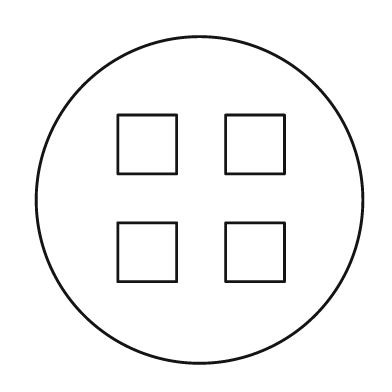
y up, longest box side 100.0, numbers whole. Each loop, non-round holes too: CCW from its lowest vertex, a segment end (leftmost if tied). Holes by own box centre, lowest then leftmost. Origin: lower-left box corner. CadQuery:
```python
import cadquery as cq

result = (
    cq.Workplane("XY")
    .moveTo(50.0, 50.0)
    .circle(50.0)
    .moveTo(25.0, 25.0)
    .lineTo(43.0, 25.0)
    .lineTo(43.0, 43.0)
    .lineTo(25.0, 43.0)
    .close()
    .moveTo(58.0, 25.0)
    .lineTo(76.0, 25.0)
    .lineTo(76.0, 43.0)
    .lineTo(58.0, 43.0)
    .close()
    .moveTo(25.0, 58.0)
    .lineTo(43.0, 58.0)
    .lineTo(43.0, 76.0)
    .lineTo(25.0, 76.0)
    .close()
    .moveTo(58.0, 58.0)
    .lineTo(76.0, 58.0)
    .lineTo(76.0, 76.0)
    .lineTo(58.0, 76.0)
    .close()
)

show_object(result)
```